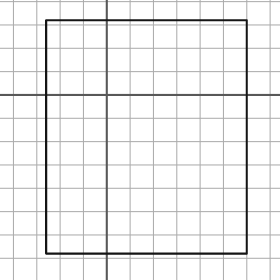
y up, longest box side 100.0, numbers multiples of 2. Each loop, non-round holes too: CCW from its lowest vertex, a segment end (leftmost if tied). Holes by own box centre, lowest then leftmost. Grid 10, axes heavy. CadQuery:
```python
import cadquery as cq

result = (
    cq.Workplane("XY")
    .moveTo(-26.0, -68.0)
    .lineTo(60.0, -68.0)
    .lineTo(60.0, 32.0)
    .lineTo(-26.0, 32.0)
    .close()
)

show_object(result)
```